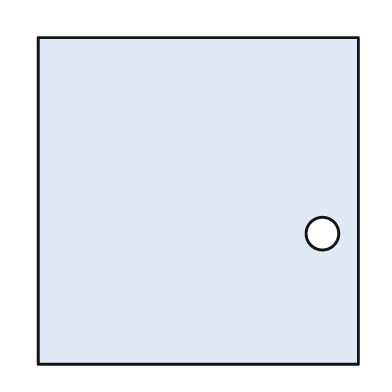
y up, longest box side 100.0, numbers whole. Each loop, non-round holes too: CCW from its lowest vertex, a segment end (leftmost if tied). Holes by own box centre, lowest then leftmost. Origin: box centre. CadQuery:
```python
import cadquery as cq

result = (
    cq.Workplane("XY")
    .moveTo(-49.0, -50.0)
    .lineTo(49.0, -50.0)
    .lineTo(49.0, 50.0)
    .lineTo(-49.0, 50.0)
    .close()
    .moveTo(38.0, -10.0)
    .circle(5.0)
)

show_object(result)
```